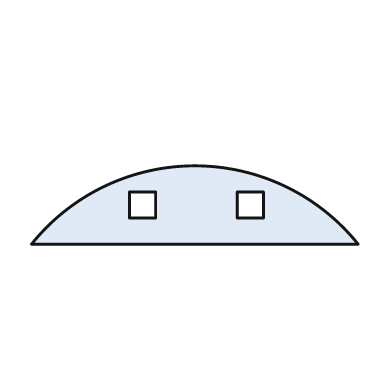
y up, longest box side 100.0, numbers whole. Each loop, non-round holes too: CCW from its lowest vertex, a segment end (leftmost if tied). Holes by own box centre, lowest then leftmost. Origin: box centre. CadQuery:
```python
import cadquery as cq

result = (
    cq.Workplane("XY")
    .moveTo(-50.0, -12.0)
    .lineTo(50.0, -12.0)
    .threePointArc((0.0, 12.0), (-50.0, -12.0))
    .close()
    .moveTo(-20.0, -4.0)
    .lineTo(-12.0, -4.0)
    .lineTo(-12.0, 4.0)
    .lineTo(-20.0, 4.0)
    .close()
    .moveTo(13.0, -4.0)
    .lineTo(21.0, -4.0)
    .lineTo(21.0, 4.0)
    .lineTo(13.0, 4.0)
    .close()
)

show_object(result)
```